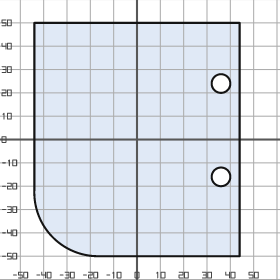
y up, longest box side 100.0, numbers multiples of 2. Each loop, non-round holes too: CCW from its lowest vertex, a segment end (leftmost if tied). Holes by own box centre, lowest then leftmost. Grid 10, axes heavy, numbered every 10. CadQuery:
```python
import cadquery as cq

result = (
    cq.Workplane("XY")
    .moveTo(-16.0, -50.0)
    .lineTo(44.0, -50.0)
    .lineTo(44.0, 50.0)
    .lineTo(-44.0, 50.0)
    .lineTo(-44.0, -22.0)
    .threePointArc((-36.0, -42.0), (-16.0, -50.0))
    .close()
    .moveTo(36.0, -16.0)
    .circle(4.0)
    .moveTo(36.0, 24.0)
    .circle(4.0)
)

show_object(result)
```